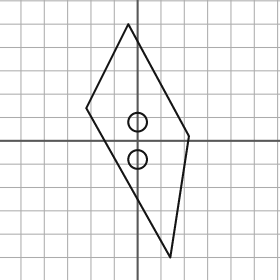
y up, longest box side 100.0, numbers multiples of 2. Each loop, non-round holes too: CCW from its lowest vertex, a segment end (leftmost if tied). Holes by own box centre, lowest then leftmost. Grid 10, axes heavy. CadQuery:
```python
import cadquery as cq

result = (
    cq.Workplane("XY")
    .moveTo(14.0, -50.0)
    .lineTo(22.0, 2.0)
    .lineTo(-4.0, 50.0)
    .lineTo(-22.0, 14.0)
    .close()
    .moveTo(0.0, -8.0)
    .circle(4.0)
    .moveTo(0.0, 8.0)
    .circle(4.0)
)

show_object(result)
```